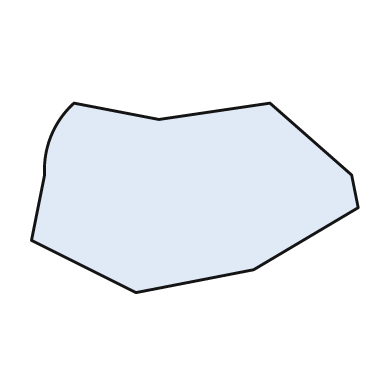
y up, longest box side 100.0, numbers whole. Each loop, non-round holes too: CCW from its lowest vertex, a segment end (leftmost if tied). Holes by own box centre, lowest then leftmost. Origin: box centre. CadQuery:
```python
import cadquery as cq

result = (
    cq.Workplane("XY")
    .moveTo(-18.0, -29.0)
    .lineTo(18.0, -22.0)
    .lineTo(50.0, -3.0)
    .lineTo(48.0, 7.0)
    .lineTo(23.0, 29.0)
    .lineTo(-11.0, 24.0)
    .lineTo(-37.0, 29.0)
    .threePointArc((-44.0, 19.0), (-46.0, 7.0))
    .lineTo(-50.0, -13.0)
    .close()
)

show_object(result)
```